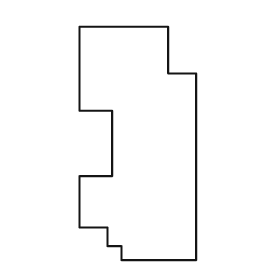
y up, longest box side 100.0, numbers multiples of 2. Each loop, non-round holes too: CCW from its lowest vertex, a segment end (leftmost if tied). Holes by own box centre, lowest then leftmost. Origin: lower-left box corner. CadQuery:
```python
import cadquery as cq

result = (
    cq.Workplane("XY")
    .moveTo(18.0, 0.0)
    .lineTo(50.0, 0.0)
    .lineTo(50.0, 80.0)
    .lineTo(38.0, 80.0)
    .lineTo(38.0, 100.0)
    .lineTo(0.0, 100.0)
    .lineTo(0.0, 64.0)
    .lineTo(14.0, 64.0)
    .lineTo(14.0, 36.0)
    .lineTo(0.0, 36.0)
    .lineTo(0.0, 14.0)
    .lineTo(12.0, 14.0)
    .lineTo(12.0, 6.0)
    .lineTo(18.0, 6.0)
    .close()
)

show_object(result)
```